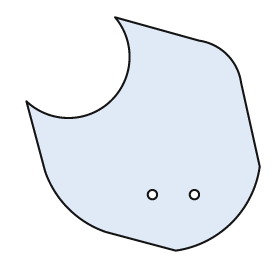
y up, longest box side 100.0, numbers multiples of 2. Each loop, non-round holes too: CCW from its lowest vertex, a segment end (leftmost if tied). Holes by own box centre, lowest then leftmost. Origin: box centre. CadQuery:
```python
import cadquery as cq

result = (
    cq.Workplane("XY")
    .moveTo(14.0, -50.0)
    .threePointArc((38.0, -38.0), (50.0, -14.0))
    .lineTo(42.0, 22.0)
    .threePointArc((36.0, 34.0), (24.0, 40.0))
    .lineTo(-12.0, 50.0)
    .threePointArc((-14.0, 14.0), (-50.0, 14.0))
    .lineTo(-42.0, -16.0)
    .threePointArc((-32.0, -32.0), (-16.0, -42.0))
    .close()
    .moveTo(4.0, -26.0)
    .circle(2.0)
    .moveTo(22.0, -26.0)
    .circle(2.0)
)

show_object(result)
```